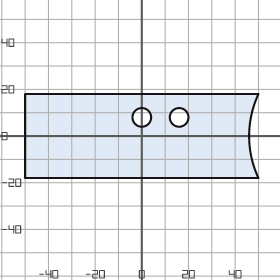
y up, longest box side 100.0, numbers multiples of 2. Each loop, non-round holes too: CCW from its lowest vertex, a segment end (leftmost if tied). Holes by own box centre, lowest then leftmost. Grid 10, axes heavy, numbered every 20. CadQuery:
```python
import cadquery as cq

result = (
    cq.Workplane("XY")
    .moveTo(-50.0, -18.0)
    .lineTo(50.0, -18.0)
    .threePointArc((46.0, 0.0), (50.0, 18.0))
    .lineTo(-50.0, 18.0)
    .close()
    .moveTo(0.0, 8.0)
    .circle(4.0)
    .moveTo(16.0, 8.0)
    .circle(4.0)
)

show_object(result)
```